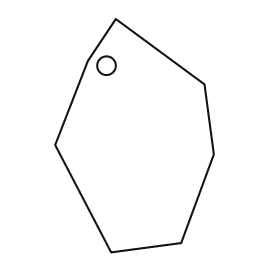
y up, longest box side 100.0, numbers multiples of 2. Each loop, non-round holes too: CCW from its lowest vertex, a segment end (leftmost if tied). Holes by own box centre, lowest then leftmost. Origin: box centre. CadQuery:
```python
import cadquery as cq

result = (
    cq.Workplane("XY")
    .moveTo(-10.0, -50.0)
    .lineTo(20.0, -46.0)
    .lineTo(34.0, -8.0)
    .lineTo(30.0, 22.0)
    .lineTo(-8.0, 50.0)
    .lineTo(-20.0, 32.0)
    .lineTo(-34.0, -4.0)
    .close()
    .moveTo(-12.0, 30.0)
    .circle(4.0)
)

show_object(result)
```